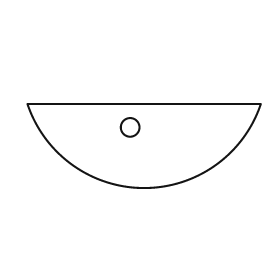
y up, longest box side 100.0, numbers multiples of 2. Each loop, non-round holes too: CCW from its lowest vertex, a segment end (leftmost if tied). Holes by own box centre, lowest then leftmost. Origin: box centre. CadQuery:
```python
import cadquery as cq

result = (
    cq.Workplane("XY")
    .moveTo(-50.0, 18.0)
    .threePointArc((0.0, -18.0), (50.0, 18.0))
    .close()
    .moveTo(-6.0, 8.0)
    .circle(4.0)
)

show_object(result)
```